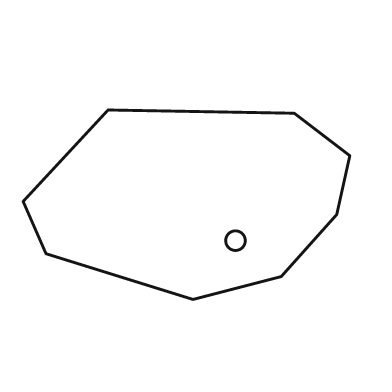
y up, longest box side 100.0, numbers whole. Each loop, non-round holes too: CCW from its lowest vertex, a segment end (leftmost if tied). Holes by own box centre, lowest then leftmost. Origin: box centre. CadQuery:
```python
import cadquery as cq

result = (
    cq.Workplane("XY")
    .moveTo(2.0, -29.0)
    .lineTo(29.0, -22.0)
    .lineTo(46.0, -3.0)
    .lineTo(50.0, 15.0)
    .lineTo(33.0, 28.0)
    .lineTo(-24.0, 29.0)
    .lineTo(-50.0, 1.0)
    .lineTo(-43.0, -15.0)
    .close()
    .moveTo(15.0, -11.0)
    .circle(3.0)
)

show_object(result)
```